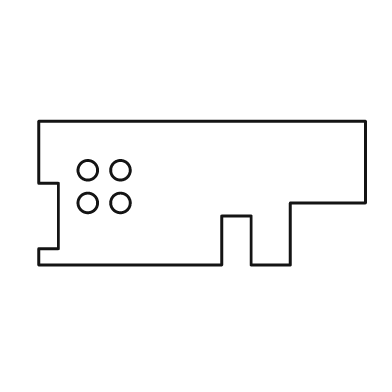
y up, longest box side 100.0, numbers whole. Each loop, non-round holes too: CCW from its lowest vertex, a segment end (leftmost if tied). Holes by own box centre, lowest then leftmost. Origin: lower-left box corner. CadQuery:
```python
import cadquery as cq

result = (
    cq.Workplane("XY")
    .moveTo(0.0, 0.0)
    .lineTo(56.0, 0.0)
    .lineTo(56.0, 15.0)
    .lineTo(65.0, 15.0)
    .lineTo(65.0, 0.0)
    .lineTo(77.0, 0.0)
    .lineTo(77.0, 19.0)
    .lineTo(100.0, 19.0)
    .lineTo(100.0, 44.0)
    .lineTo(0.0, 44.0)
    .lineTo(0.0, 25.0)
    .lineTo(6.0, 25.0)
    .lineTo(6.0, 5.0)
    .lineTo(0.0, 5.0)
    .close()
    .moveTo(15.0, 19.0)
    .circle(3.0)
    .moveTo(25.0, 19.0)
    .circle(3.0)
    .moveTo(15.0, 29.0)
    .circle(3.0)
    .moveTo(25.0, 29.0)
    .circle(3.0)
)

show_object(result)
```